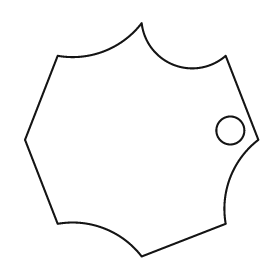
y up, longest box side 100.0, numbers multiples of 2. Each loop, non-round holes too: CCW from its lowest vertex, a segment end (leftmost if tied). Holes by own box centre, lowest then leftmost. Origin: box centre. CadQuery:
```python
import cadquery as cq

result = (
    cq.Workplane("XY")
    .moveTo(0.0, -50.0)
    .lineTo(36.0, -36.0)
    .threePointArc((38.0, -16.0), (50.0, 0.0))
    .lineTo(36.0, 36.0)
    .threePointArc((14.0, 32.0), (0.0, 50.0))
    .threePointArc((-16.0, 38.0), (-36.0, 36.0))
    .lineTo(-50.0, 0.0)
    .lineTo(-36.0, -36.0)
    .threePointArc((-16.0, -38.0), (0.0, -50.0))
    .close()
    .moveTo(38.0, 4.0)
    .circle(6.0)
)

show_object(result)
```